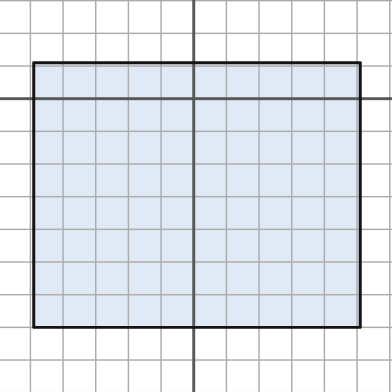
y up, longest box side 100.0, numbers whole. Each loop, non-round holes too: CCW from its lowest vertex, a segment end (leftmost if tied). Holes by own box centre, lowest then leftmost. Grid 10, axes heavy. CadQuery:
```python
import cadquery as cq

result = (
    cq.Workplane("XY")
    .moveTo(-49.0, -70.0)
    .lineTo(51.0, -70.0)
    .lineTo(51.0, 11.0)
    .lineTo(-49.0, 11.0)
    .close()
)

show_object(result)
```